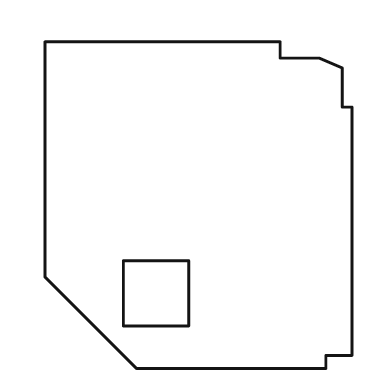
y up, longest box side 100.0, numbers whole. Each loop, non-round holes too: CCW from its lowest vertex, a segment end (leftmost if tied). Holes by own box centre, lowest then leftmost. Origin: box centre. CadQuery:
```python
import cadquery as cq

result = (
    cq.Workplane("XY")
    .moveTo(-19.0, -50.0)
    .lineTo(39.0, -50.0)
    .lineTo(39.0, -46.0)
    .lineTo(47.0, -46.0)
    .lineTo(47.0, 30.0)
    .lineTo(44.0, 30.0)
    .lineTo(44.0, 42.0)
    .lineTo(37.0, 45.0)
    .lineTo(25.0, 45.0)
    .lineTo(25.0, 50.0)
    .lineTo(-47.0, 50.0)
    .lineTo(-47.0, -22.0)
    .close()
    .moveTo(-23.0, -37.0)
    .lineTo(-3.0, -37.0)
    .lineTo(-3.0, -17.0)
    .lineTo(-23.0, -17.0)
    .close()
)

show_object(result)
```